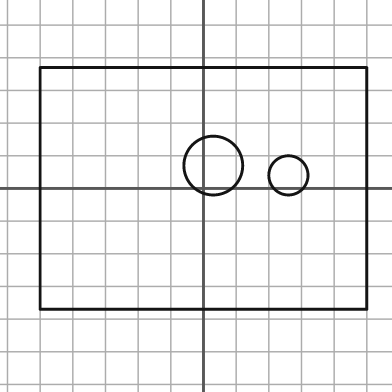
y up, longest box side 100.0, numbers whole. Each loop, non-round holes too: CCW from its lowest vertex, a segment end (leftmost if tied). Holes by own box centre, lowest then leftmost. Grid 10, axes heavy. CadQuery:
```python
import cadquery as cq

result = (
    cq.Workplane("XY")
    .moveTo(-50.0, -37.0)
    .lineTo(50.0, -37.0)
    .lineTo(50.0, 37.0)
    .lineTo(-50.0, 37.0)
    .close()
    .moveTo(26.0, 4.0)
    .circle(6.0)
    .moveTo(3.0, 7.0)
    .circle(9.0)
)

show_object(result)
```